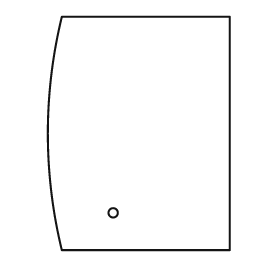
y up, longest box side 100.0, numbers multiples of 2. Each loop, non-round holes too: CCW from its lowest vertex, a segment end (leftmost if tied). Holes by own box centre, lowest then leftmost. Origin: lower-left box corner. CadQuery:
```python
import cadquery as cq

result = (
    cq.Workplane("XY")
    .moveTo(6.0, 0.0)
    .lineTo(78.0, 0.0)
    .lineTo(78.0, 100.0)
    .lineTo(6.0, 100.0)
    .threePointArc((0.0, 50.0), (6.0, 0.0))
    .close()
    .moveTo(28.0, 16.0)
    .circle(2.0)
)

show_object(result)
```